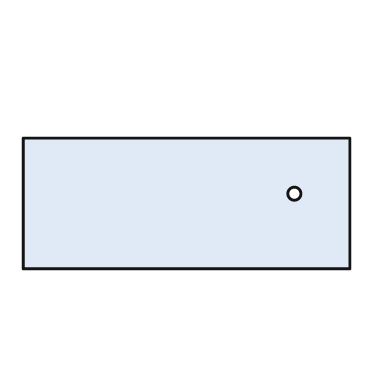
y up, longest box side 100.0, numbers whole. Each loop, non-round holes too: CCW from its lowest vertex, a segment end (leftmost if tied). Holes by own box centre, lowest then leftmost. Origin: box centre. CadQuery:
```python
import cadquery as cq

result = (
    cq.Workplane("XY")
    .moveTo(-50.0, -20.0)
    .lineTo(50.0, -20.0)
    .lineTo(50.0, 20.0)
    .lineTo(-50.0, 20.0)
    .close()
    .moveTo(33.0, 3.0)
    .circle(2.0)
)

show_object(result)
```